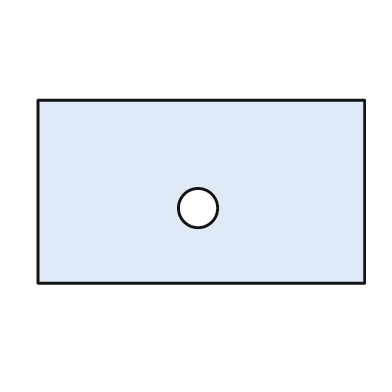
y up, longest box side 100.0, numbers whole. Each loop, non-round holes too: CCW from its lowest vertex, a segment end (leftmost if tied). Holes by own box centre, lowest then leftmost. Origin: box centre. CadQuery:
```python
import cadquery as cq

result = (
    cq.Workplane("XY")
    .moveTo(-50.0, -28.0)
    .lineTo(50.0, -28.0)
    .lineTo(50.0, 28.0)
    .lineTo(-50.0, 28.0)
    .close()
    .moveTo(-1.0, -5.0)
    .circle(6.0)
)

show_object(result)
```